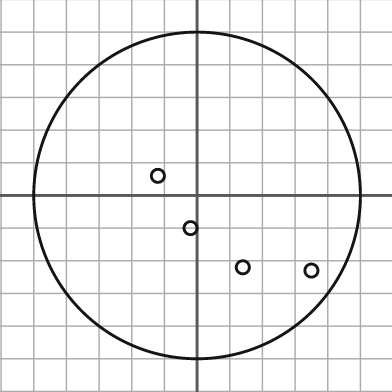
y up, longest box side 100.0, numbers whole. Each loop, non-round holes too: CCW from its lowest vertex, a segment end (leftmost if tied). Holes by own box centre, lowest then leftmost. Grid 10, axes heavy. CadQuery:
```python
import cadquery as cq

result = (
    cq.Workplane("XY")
    .moveTo(0.0, 0.0)
    .circle(50.0)
    .moveTo(35.0, -23.0)
    .circle(2.0)
    .moveTo(14.0, -22.0)
    .circle(2.0)
    .moveTo(-2.0, -10.0)
    .circle(2.0)
    .moveTo(-12.0, 6.0)
    .circle(2.0)
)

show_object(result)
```